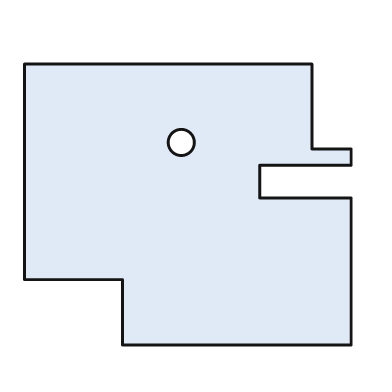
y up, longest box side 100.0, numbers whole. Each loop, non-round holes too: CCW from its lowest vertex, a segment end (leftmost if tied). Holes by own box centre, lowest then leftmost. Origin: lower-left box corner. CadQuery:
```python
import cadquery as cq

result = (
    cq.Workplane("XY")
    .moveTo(30.0, 0.0)
    .lineTo(100.0, 0.0)
    .lineTo(100.0, 45.0)
    .lineTo(72.0, 45.0)
    .lineTo(72.0, 55.0)
    .lineTo(100.0, 55.0)
    .lineTo(100.0, 60.0)
    .lineTo(88.0, 60.0)
    .lineTo(88.0, 86.0)
    .lineTo(0.0, 86.0)
    .lineTo(0.0, 20.0)
    .lineTo(30.0, 20.0)
    .close()
    .moveTo(48.0, 62.0)
    .circle(4.0)
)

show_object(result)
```